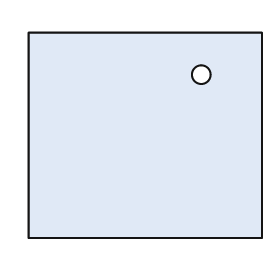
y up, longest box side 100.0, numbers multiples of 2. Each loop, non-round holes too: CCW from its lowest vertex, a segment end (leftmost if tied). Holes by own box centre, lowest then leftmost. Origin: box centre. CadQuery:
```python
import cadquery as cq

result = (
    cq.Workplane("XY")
    .moveTo(-50.0, -44.0)
    .lineTo(50.0, -44.0)
    .lineTo(50.0, 44.0)
    .lineTo(-50.0, 44.0)
    .close()
    .moveTo(24.0, 26.0)
    .circle(4.0)
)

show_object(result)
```